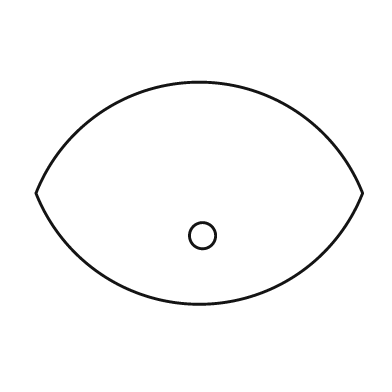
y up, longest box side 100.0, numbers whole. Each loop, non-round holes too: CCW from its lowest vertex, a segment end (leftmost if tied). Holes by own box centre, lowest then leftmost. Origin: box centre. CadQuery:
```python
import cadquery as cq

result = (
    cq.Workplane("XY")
    .moveTo(-50.0, 0.0)
    .threePointArc((0.0, -34.0), (50.0, 0.0))
    .threePointArc((0.0, 34.0), (-50.0, 0.0))
    .close()
    .moveTo(1.0, -13.0)
    .circle(4.0)
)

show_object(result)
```